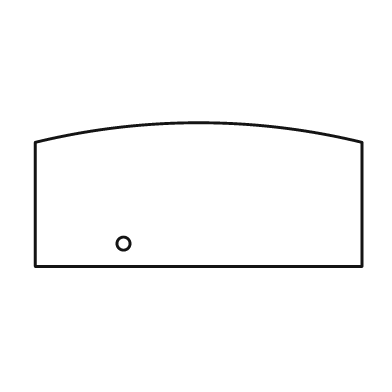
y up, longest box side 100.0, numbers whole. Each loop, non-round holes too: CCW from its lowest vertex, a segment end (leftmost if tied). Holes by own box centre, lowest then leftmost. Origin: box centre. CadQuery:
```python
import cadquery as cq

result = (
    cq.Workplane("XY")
    .moveTo(-50.0, -22.0)
    .lineTo(50.0, -22.0)
    .lineTo(50.0, 16.0)
    .threePointArc((0.0, 22.0), (-50.0, 16.0))
    .close()
    .moveTo(-23.0, -15.0)
    .circle(2.0)
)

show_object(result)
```